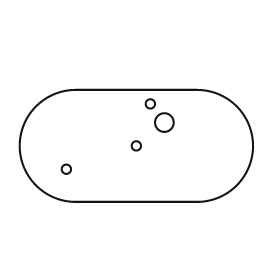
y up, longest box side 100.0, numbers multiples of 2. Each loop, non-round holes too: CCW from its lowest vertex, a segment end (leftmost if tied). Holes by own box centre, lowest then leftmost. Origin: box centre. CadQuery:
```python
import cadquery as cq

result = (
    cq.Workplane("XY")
    .moveTo(-26.0, -24.0)
    .lineTo(26.0, -24.0)
    .threePointArc((50.0, 0.0), (26.0, 24.0))
    .lineTo(-26.0, 24.0)
    .threePointArc((-50.0, 0.0), (-26.0, -24.0))
    .close()
    .moveTo(-30.0, -10.0)
    .circle(2.0)
    .moveTo(0.0, 0.0)
    .circle(2.0)
    .moveTo(12.0, 10.0)
    .circle(4.0)
    .moveTo(6.0, 18.0)
    .circle(2.0)
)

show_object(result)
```